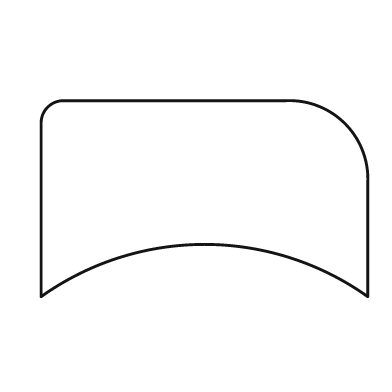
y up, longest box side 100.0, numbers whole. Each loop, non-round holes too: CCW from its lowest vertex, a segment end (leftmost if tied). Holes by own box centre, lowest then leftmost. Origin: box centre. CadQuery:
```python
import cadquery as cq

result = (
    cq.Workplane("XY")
    .moveTo(-50.0, -30.0)
    .threePointArc((0.0, -14.0), (50.0, -30.0))
    .lineTo(50.0, 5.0)
    .threePointArc((43.0, 23.0), (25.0, 30.0))
    .lineTo(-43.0, 30.0)
    .threePointArc((-48.0, 28.0), (-50.0, 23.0))
    .close()
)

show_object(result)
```